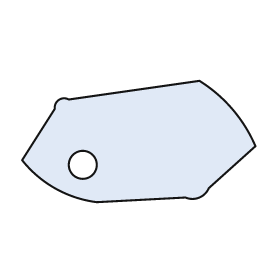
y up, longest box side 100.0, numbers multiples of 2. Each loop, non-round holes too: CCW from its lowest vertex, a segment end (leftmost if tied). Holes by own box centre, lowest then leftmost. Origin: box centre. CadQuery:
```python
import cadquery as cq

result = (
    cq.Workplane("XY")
    .moveTo(-18.0, -26.0)
    .lineTo(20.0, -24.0)
    .threePointArc((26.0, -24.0), (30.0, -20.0))
    .lineTo(50.0, -2.0)
    .threePointArc((40.0, 14.0), (26.0, 26.0))
    .lineTo(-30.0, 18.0)
    .threePointArc((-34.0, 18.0), (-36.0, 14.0))
    .lineTo(-50.0, -8.0)
    .threePointArc((-36.0, -20.0), (-18.0, -26.0))
    .close()
    .moveTo(-24.0, -10.0)
    .circle(6.0)
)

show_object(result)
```